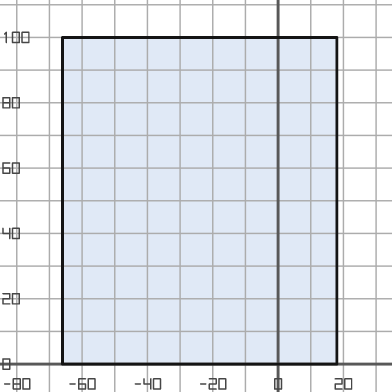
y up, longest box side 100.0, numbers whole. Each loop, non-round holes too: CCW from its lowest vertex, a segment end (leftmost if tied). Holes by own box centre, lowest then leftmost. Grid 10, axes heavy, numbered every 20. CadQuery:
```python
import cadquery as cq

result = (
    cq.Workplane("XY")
    .moveTo(-66.0, 0.0)
    .lineTo(18.0, 0.0)
    .lineTo(18.0, 100.0)
    .lineTo(-66.0, 100.0)
    .close()
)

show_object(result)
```